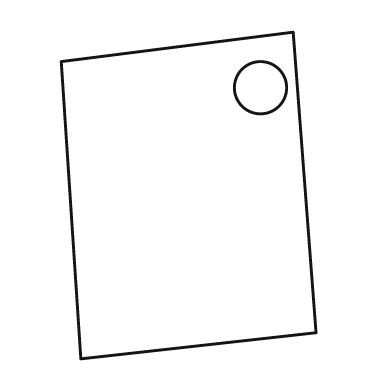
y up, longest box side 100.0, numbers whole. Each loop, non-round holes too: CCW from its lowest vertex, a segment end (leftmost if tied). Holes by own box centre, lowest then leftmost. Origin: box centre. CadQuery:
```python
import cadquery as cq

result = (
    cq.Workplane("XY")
    .moveTo(-33.0, -50.0)
    .lineTo(39.0, -42.0)
    .lineTo(32.0, 50.0)
    .lineTo(-39.0, 41.0)
    .close()
    .moveTo(22.0, 33.0)
    .circle(8.0)
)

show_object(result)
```